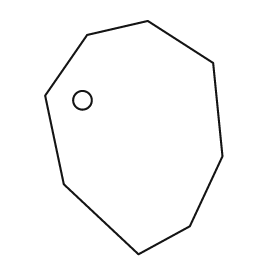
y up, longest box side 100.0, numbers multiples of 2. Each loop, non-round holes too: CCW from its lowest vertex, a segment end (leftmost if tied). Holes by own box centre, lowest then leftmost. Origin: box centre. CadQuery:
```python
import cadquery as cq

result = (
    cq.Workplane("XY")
    .moveTo(2.0, -50.0)
    .lineTo(24.0, -38.0)
    .lineTo(38.0, -8.0)
    .lineTo(34.0, 32.0)
    .lineTo(6.0, 50.0)
    .lineTo(-20.0, 44.0)
    .lineTo(-38.0, 18.0)
    .lineTo(-30.0, -20.0)
    .close()
    .moveTo(-22.0, 16.0)
    .circle(4.0)
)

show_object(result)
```